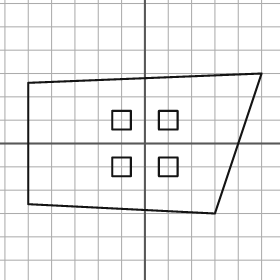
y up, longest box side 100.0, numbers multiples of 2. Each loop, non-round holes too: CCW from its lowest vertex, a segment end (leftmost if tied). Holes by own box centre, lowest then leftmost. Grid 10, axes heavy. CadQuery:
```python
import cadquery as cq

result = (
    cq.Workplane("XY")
    .moveTo(30.0, -30.0)
    .lineTo(50.0, 30.0)
    .lineTo(-50.0, 26.0)
    .lineTo(-50.0, -26.0)
    .close()
    .moveTo(-14.0, -14.0)
    .lineTo(-6.0, -14.0)
    .lineTo(-6.0, -6.0)
    .lineTo(-14.0, -6.0)
    .close()
    .moveTo(6.0, -14.0)
    .lineTo(14.0, -14.0)
    .lineTo(14.0, -6.0)
    .lineTo(6.0, -6.0)
    .close()
    .moveTo(-14.0, 6.0)
    .lineTo(-6.0, 6.0)
    .lineTo(-6.0, 14.0)
    .lineTo(-14.0, 14.0)
    .close()
    .moveTo(6.0, 6.0)
    .lineTo(14.0, 6.0)
    .lineTo(14.0, 14.0)
    .lineTo(6.0, 14.0)
    .close()
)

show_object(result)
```